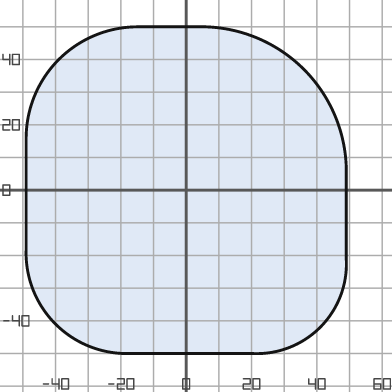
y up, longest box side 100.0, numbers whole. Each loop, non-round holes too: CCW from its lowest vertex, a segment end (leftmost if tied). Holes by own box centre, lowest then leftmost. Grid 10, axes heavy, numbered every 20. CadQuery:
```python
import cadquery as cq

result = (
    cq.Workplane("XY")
    .moveTo(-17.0, -50.0)
    .lineTo(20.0, -50.0)
    .threePointArc((41.0, -42.0), (49.0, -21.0))
    .lineTo(49.0, 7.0)
    .threePointArc((36.0, 37.0), (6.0, 50.0))
    .lineTo(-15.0, 50.0)
    .threePointArc((-39.0, 40.0), (-49.0, 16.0))
    .lineTo(-49.0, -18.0)
    .threePointArc((-40.0, -41.0), (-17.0, -50.0))
    .close()
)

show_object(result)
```